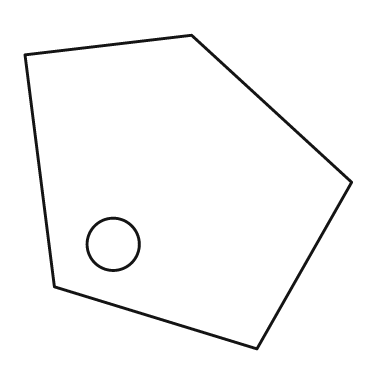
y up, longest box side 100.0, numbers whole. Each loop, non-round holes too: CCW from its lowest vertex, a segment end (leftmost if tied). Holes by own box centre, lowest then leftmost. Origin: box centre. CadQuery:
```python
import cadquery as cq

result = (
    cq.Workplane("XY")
    .moveTo(21.0, -48.0)
    .lineTo(50.0, 3.0)
    .lineTo(1.0, 48.0)
    .lineTo(-50.0, 42.0)
    .lineTo(-41.0, -29.0)
    .close()
    .moveTo(-23.0, -16.0)
    .circle(8.0)
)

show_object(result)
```